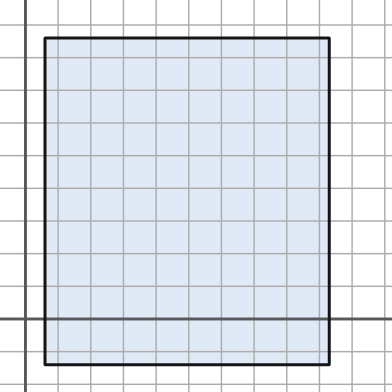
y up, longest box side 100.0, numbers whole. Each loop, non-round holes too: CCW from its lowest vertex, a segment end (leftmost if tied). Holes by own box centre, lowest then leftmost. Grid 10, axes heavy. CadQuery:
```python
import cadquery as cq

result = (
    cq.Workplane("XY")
    .moveTo(6.0, -14.0)
    .lineTo(93.0, -14.0)
    .lineTo(93.0, 86.0)
    .lineTo(6.0, 86.0)
    .close()
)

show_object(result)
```